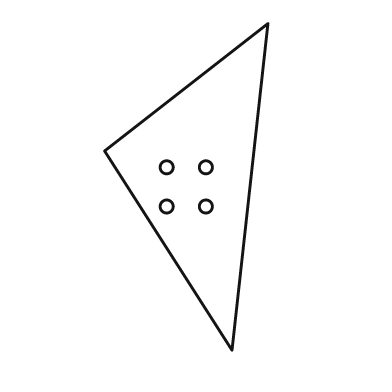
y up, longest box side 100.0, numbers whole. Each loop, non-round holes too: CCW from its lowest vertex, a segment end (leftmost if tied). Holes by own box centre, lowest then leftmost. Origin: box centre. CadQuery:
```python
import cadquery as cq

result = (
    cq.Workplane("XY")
    .moveTo(14.0, -50.0)
    .lineTo(25.0, 50.0)
    .lineTo(-25.0, 11.0)
    .close()
    .moveTo(-6.0, -6.0)
    .circle(2.0)
    .moveTo(6.0, -6.0)
    .circle(2.0)
    .moveTo(-6.0, 6.0)
    .circle(2.0)
    .moveTo(6.0, 6.0)
    .circle(2.0)
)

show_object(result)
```